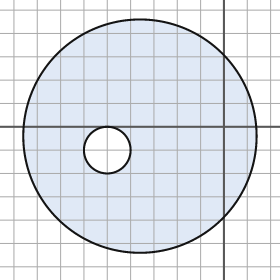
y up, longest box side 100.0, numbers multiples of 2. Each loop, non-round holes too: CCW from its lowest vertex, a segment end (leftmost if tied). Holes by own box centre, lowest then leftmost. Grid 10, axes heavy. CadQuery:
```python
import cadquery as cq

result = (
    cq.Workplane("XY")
    .moveTo(-36.0, -4.0)
    .circle(50.0)
    .moveTo(-50.0, -10.0)
    .circle(10.0)
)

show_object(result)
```